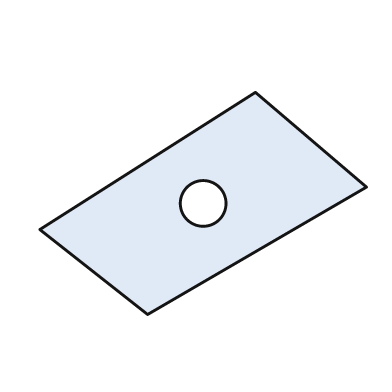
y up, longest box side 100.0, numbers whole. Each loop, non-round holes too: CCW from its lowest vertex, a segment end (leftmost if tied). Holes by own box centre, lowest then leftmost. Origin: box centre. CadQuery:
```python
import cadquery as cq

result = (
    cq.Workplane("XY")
    .moveTo(-17.0, -34.0)
    .lineTo(50.0, 5.0)
    .lineTo(16.0, 34.0)
    .lineTo(-50.0, -8.0)
    .close()
    .moveTo(0.0, 0.0)
    .circle(7.0)
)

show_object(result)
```